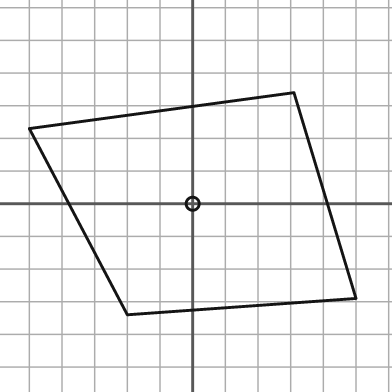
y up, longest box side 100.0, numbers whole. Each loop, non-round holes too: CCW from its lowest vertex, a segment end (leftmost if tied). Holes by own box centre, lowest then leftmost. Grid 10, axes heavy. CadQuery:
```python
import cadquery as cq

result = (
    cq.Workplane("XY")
    .moveTo(-20.0, -34.0)
    .lineTo(50.0, -29.0)
    .lineTo(31.0, 34.0)
    .lineTo(-50.0, 23.0)
    .close()
    .moveTo(0.0, 0.0)
    .circle(2.0)
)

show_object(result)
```